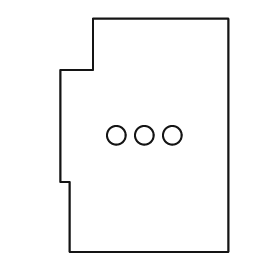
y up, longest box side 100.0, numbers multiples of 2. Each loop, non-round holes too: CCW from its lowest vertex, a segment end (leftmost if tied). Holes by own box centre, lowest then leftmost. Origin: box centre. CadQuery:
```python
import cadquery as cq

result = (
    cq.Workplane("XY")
    .moveTo(-32.0, -50.0)
    .lineTo(36.0, -50.0)
    .lineTo(36.0, 50.0)
    .lineTo(-22.0, 50.0)
    .lineTo(-22.0, 28.0)
    .lineTo(-36.0, 28.0)
    .lineTo(-36.0, -20.0)
    .lineTo(-32.0, -20.0)
    .close()
    .moveTo(-12.0, 0.0)
    .circle(4.0)
    .moveTo(0.0, 0.0)
    .circle(4.0)
    .moveTo(12.0, 0.0)
    .circle(4.0)
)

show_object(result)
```